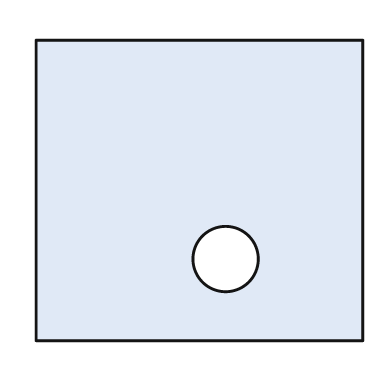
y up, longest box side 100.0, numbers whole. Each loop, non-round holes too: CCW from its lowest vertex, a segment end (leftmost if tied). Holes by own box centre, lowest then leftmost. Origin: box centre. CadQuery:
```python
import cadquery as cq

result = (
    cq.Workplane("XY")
    .moveTo(-50.0, -46.0)
    .lineTo(50.0, -46.0)
    .lineTo(50.0, 46.0)
    .lineTo(-50.0, 46.0)
    .close()
    .moveTo(8.0, -21.0)
    .circle(10.0)
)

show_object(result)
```